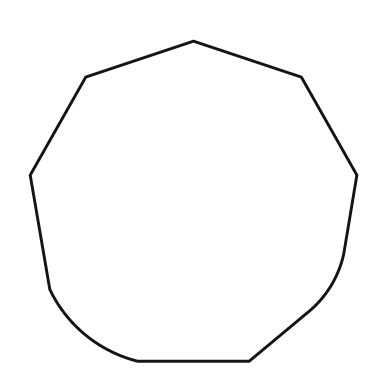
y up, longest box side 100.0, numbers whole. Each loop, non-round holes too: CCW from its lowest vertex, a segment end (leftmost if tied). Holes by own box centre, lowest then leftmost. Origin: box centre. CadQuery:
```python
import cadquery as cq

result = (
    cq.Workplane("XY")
    .moveTo(-17.0, -49.0)
    .lineTo(17.0, -49.0)
    .lineTo(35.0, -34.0)
    .threePointArc((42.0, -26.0), (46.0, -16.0))
    .lineTo(50.0, 8.0)
    .lineTo(33.0, 38.0)
    .lineTo(0.0, 49.0)
    .lineTo(-33.0, 38.0)
    .lineTo(-50.0, 8.0)
    .lineTo(-44.0, -27.0)
    .threePointArc((-33.0, -41.0), (-17.0, -49.0))
    .close()
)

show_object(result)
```